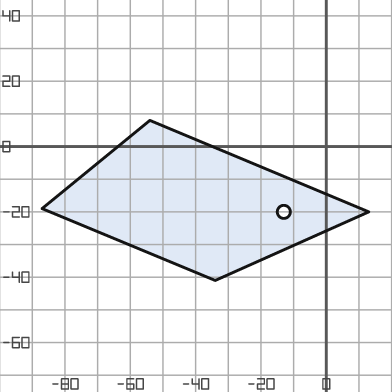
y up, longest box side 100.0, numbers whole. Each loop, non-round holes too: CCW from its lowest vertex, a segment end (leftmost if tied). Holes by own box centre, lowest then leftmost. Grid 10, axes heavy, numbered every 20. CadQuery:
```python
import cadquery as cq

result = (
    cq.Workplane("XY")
    .moveTo(-34.0, -41.0)
    .lineTo(13.0, -20.0)
    .lineTo(-54.0, 8.0)
    .lineTo(-87.0, -19.0)
    .close()
    .moveTo(-13.0, -20.0)
    .circle(2.0)
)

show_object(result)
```